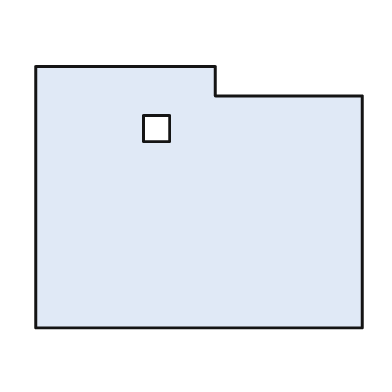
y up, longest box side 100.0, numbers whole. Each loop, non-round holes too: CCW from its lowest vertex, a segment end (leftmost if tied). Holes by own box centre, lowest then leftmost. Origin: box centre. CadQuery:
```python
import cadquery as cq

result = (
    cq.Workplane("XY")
    .moveTo(-50.0, -40.0)
    .lineTo(50.0, -40.0)
    .lineTo(50.0, 31.0)
    .lineTo(5.0, 31.0)
    .lineTo(5.0, 40.0)
    .lineTo(-50.0, 40.0)
    .close()
    .moveTo(-17.0, 17.0)
    .lineTo(-9.0, 17.0)
    .lineTo(-9.0, 25.0)
    .lineTo(-17.0, 25.0)
    .close()
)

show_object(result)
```